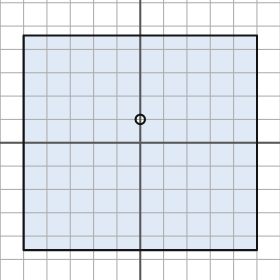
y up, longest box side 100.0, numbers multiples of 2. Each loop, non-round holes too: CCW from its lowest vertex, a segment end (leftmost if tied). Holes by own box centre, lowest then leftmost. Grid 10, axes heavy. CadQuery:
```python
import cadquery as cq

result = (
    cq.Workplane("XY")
    .moveTo(-50.0, -46.0)
    .lineTo(50.0, -46.0)
    .lineTo(50.0, 46.0)
    .lineTo(-50.0, 46.0)
    .close()
    .moveTo(0.0, 10.0)
    .circle(2.0)
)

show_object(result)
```